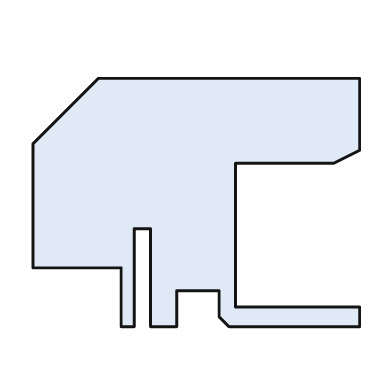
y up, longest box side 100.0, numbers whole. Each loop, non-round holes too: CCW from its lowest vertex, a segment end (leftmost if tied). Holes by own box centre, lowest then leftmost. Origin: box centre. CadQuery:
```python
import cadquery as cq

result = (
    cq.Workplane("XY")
    .moveTo(-23.0, -38.0)
    .lineTo(-19.0, -38.0)
    .lineTo(-19.0, -8.0)
    .lineTo(-14.0, -8.0)
    .lineTo(-14.0, -38.0)
    .lineTo(-6.0, -38.0)
    .lineTo(-6.0, -27.0)
    .lineTo(7.0, -27.0)
    .lineTo(7.0, -35.0)
    .lineTo(10.0, -38.0)
    .lineTo(50.0, -38.0)
    .lineTo(50.0, -32.0)
    .lineTo(12.0, -32.0)
    .lineTo(12.0, 12.0)
    .lineTo(42.0, 12.0)
    .lineTo(50.0, 16.0)
    .lineTo(50.0, 38.0)
    .lineTo(-30.0, 38.0)
    .lineTo(-50.0, 18.0)
    .lineTo(-50.0, -20.0)
    .lineTo(-23.0, -20.0)
    .close()
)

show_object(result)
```